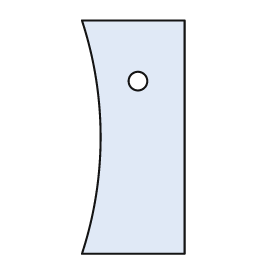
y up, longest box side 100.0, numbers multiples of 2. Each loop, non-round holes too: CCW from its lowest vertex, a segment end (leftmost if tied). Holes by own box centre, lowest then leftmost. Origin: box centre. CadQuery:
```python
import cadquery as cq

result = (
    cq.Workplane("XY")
    .moveTo(-22.0, -50.0)
    .lineTo(22.0, -50.0)
    .lineTo(22.0, 50.0)
    .lineTo(-22.0, 50.0)
    .threePointArc((-14.0, 0.0), (-22.0, -50.0))
    .close()
    .moveTo(2.0, 24.0)
    .circle(4.0)
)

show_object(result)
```